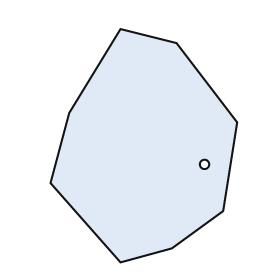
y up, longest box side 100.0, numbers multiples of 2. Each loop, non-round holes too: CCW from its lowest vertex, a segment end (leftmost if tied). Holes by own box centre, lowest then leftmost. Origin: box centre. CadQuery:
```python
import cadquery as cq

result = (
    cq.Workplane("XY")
    .moveTo(-10.0, -50.0)
    .lineTo(12.0, -44.0)
    .lineTo(34.0, -28.0)
    .lineTo(40.0, 10.0)
    .lineTo(14.0, 44.0)
    .lineTo(-10.0, 50.0)
    .lineTo(-32.0, 14.0)
    .lineTo(-40.0, -16.0)
    .close()
    .moveTo(26.0, -8.0)
    .circle(2.0)
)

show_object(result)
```